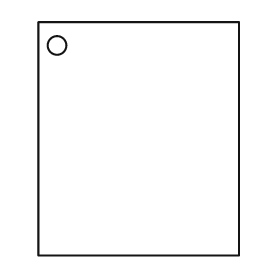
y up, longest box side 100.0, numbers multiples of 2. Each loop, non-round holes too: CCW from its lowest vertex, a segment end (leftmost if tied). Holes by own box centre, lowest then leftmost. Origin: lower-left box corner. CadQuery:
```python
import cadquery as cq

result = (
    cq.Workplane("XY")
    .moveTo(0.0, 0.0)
    .lineTo(86.0, 0.0)
    .lineTo(86.0, 100.0)
    .lineTo(0.0, 100.0)
    .close()
    .moveTo(8.0, 90.0)
    .circle(4.0)
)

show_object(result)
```